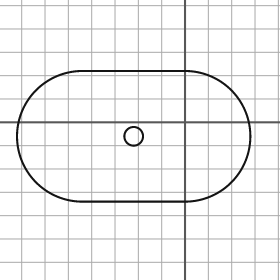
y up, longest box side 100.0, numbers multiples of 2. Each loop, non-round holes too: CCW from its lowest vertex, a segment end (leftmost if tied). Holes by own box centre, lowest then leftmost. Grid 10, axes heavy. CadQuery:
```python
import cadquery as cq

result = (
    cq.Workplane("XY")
    .moveTo(-44.0, -34.0)
    .lineTo(0.0, -34.0)
    .threePointArc((28.0, -6.0), (0.0, 22.0))
    .lineTo(-44.0, 22.0)
    .threePointArc((-72.0, -6.0), (-44.0, -34.0))
    .close()
    .moveTo(-22.0, -6.0)
    .circle(4.0)
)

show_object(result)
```